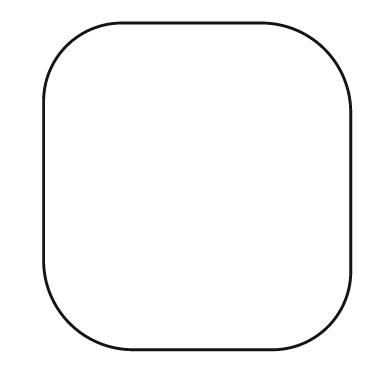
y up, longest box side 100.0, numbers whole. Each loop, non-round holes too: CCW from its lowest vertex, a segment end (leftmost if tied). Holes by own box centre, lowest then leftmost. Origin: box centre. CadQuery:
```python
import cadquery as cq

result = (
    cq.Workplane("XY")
    .moveTo(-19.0, -50.0)
    .lineTo(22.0, -50.0)
    .threePointArc((40.0, -43.0), (47.0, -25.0))
    .lineTo(47.0, 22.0)
    .threePointArc((39.0, 42.0), (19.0, 50.0))
    .lineTo(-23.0, 50.0)
    .threePointArc((-40.0, 43.0), (-47.0, 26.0))
    .lineTo(-47.0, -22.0)
    .threePointArc((-39.0, -42.0), (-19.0, -50.0))
    .close()
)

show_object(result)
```